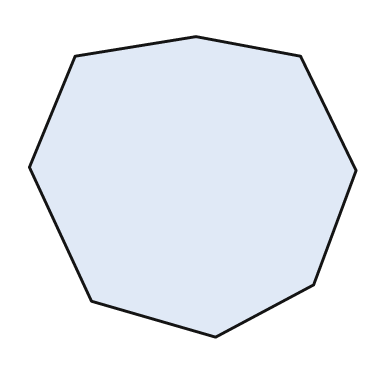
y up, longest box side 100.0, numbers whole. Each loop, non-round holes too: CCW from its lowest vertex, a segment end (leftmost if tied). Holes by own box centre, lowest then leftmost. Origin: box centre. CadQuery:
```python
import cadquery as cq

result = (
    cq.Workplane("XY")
    .moveTo(7.0, -46.0)
    .lineTo(37.0, -30.0)
    .lineTo(50.0, 5.0)
    .lineTo(33.0, 40.0)
    .lineTo(1.0, 46.0)
    .lineTo(-36.0, 40.0)
    .lineTo(-50.0, 6.0)
    .lineTo(-31.0, -35.0)
    .close()
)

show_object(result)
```